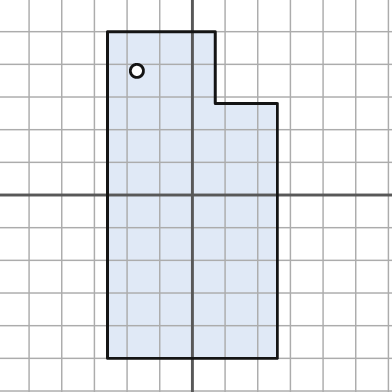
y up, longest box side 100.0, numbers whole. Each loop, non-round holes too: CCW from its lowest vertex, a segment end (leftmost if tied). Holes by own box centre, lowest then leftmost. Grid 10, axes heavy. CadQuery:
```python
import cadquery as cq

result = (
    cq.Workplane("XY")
    .moveTo(-26.0, -50.0)
    .lineTo(26.0, -50.0)
    .lineTo(26.0, 28.0)
    .lineTo(7.0, 28.0)
    .lineTo(7.0, 50.0)
    .lineTo(-26.0, 50.0)
    .close()
    .moveTo(-17.0, 38.0)
    .circle(2.0)
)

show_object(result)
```